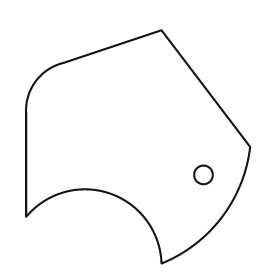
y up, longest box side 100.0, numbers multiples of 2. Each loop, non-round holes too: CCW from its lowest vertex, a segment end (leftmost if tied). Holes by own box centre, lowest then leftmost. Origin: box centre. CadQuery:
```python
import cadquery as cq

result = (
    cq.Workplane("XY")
    .moveTo(10.0, -50.0)
    .threePointArc((36.0, -30.0), (48.0, 0.0))
    .lineTo(10.0, 50.0)
    .lineTo(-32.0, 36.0)
    .threePointArc((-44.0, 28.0), (-48.0, 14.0))
    .lineTo(-48.0, -30.0)
    .threePointArc((-12.0, -20.0), (10.0, -50.0))
    .close()
    .moveTo(28.0, -12.0)
    .circle(4.0)
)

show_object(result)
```